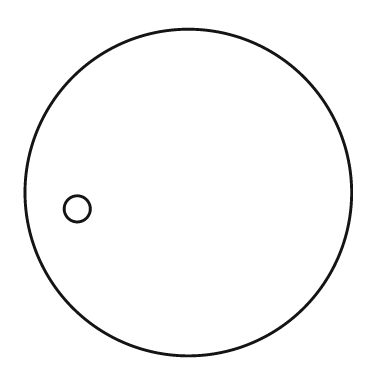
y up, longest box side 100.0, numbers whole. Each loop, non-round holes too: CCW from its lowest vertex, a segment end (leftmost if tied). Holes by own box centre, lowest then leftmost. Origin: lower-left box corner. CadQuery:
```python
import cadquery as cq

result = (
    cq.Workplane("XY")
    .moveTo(50.0, 50.0)
    .circle(50.0)
    .moveTo(16.0, 45.0)
    .circle(4.0)
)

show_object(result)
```